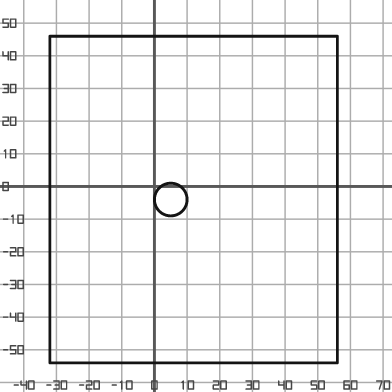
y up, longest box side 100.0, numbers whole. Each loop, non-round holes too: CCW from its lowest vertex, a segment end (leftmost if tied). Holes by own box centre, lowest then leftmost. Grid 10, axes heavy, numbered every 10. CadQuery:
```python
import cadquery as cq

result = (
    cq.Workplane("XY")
    .moveTo(-32.0, -54.0)
    .lineTo(56.0, -54.0)
    .lineTo(56.0, 46.0)
    .lineTo(-32.0, 46.0)
    .close()
    .moveTo(5.0, -4.0)
    .circle(5.0)
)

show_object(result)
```